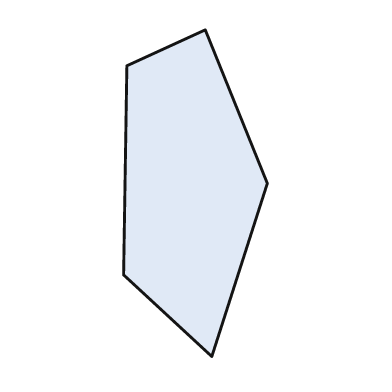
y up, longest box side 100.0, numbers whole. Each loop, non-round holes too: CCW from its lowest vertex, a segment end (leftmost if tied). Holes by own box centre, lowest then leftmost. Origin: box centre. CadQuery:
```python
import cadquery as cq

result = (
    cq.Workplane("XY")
    .moveTo(5.0, -50.0)
    .lineTo(22.0, 3.0)
    .lineTo(3.0, 50.0)
    .lineTo(-21.0, 39.0)
    .lineTo(-22.0, -25.0)
    .close()
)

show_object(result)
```